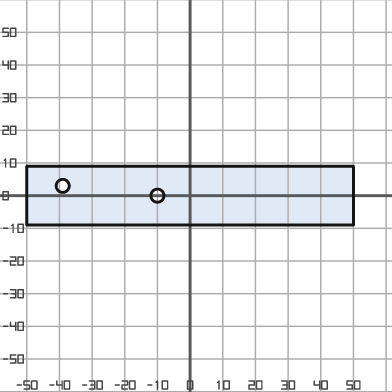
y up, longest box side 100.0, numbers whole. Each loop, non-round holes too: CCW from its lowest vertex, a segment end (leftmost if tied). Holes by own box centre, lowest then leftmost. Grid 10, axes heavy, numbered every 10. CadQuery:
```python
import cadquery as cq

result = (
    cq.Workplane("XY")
    .moveTo(-50.0, -9.0)
    .lineTo(50.0, -9.0)
    .lineTo(50.0, 9.0)
    .lineTo(-50.0, 9.0)
    .close()
    .moveTo(-10.0, 0.0)
    .circle(2.0)
    .moveTo(-39.0, 3.0)
    .circle(2.0)
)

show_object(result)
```